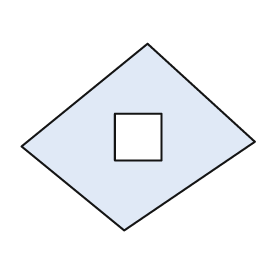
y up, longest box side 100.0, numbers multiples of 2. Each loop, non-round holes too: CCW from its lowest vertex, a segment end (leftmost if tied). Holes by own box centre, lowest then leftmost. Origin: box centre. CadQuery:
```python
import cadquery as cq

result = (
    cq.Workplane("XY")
    .moveTo(-6.0, -40.0)
    .lineTo(50.0, -2.0)
    .lineTo(4.0, 40.0)
    .lineTo(-50.0, -4.0)
    .close()
    .moveTo(-10.0, -10.0)
    .lineTo(10.0, -10.0)
    .lineTo(10.0, 10.0)
    .lineTo(-10.0, 10.0)
    .close()
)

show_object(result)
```